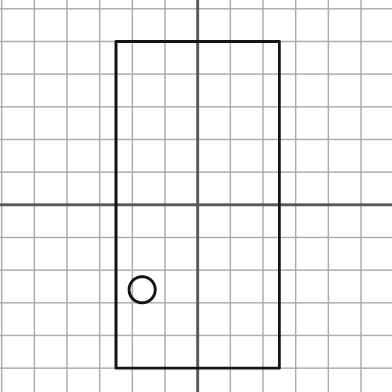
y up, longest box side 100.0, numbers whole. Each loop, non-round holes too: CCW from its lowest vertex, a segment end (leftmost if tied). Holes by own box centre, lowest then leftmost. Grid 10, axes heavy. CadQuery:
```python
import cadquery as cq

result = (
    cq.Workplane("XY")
    .moveTo(-25.0, -50.0)
    .lineTo(25.0, -50.0)
    .lineTo(25.0, 50.0)
    .lineTo(-25.0, 50.0)
    .close()
    .moveTo(-17.0, -26.0)
    .circle(4.0)
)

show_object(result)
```